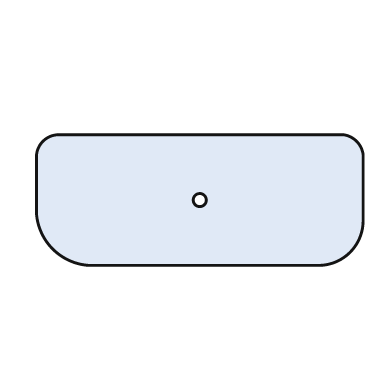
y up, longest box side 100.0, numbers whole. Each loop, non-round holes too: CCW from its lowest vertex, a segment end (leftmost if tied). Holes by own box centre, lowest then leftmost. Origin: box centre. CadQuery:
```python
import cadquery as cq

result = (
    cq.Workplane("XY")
    .moveTo(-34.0, -20.0)
    .lineTo(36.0, -20.0)
    .threePointArc((46.0, -16.0), (50.0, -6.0))
    .lineTo(50.0, 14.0)
    .threePointArc((48.0, 18.0), (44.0, 20.0))
    .lineTo(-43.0, 20.0)
    .threePointArc((-48.0, 18.0), (-50.0, 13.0))
    .lineTo(-50.0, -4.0)
    .threePointArc((-45.0, -15.0), (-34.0, -20.0))
    .close()
    .moveTo(0.0, 0.0)
    .circle(2.0)
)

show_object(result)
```